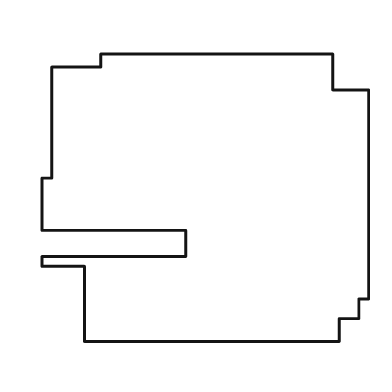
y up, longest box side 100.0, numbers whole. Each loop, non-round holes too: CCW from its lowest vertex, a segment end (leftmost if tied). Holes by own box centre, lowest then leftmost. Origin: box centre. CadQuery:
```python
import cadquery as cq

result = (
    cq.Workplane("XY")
    .moveTo(-37.0, -44.0)
    .lineTo(41.0, -44.0)
    .lineTo(41.0, -37.0)
    .lineTo(47.0, -37.0)
    .lineTo(47.0, -31.0)
    .lineTo(50.0, -31.0)
    .lineTo(50.0, 33.0)
    .lineTo(39.0, 33.0)
    .lineTo(39.0, 44.0)
    .lineTo(-32.0, 44.0)
    .lineTo(-32.0, 40.0)
    .lineTo(-47.0, 40.0)
    .lineTo(-47.0, 6.0)
    .lineTo(-50.0, 6.0)
    .lineTo(-50.0, -10.0)
    .lineTo(-6.0, -10.0)
    .lineTo(-6.0, -18.0)
    .lineTo(-50.0, -18.0)
    .lineTo(-50.0, -21.0)
    .lineTo(-37.0, -21.0)
    .close()
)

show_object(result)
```